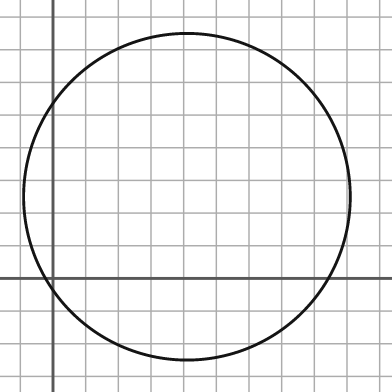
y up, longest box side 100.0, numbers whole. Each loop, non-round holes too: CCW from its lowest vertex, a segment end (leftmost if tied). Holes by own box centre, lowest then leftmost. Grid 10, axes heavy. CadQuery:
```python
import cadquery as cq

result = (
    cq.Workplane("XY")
    .moveTo(41.0, 25.0)
    .circle(50.0)
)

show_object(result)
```